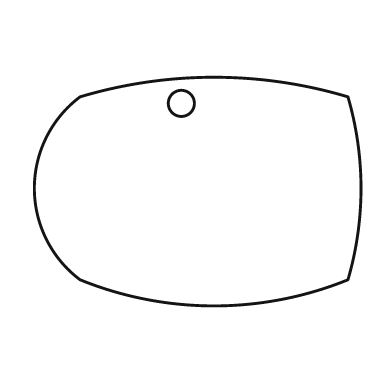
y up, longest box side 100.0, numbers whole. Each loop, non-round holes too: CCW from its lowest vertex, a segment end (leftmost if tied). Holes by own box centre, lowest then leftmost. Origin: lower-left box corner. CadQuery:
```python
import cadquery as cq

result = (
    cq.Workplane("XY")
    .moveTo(14.0, 8.0)
    .threePointArc((55.0, 0.0), (96.0, 8.0))
    .threePointArc((100.0, 36.0), (96.0, 64.0))
    .threePointArc((55.0, 70.0), (14.0, 64.0))
    .threePointArc((0.0, 36.0), (14.0, 8.0))
    .close()
    .moveTo(45.0, 62.0)
    .circle(4.0)
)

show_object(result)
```